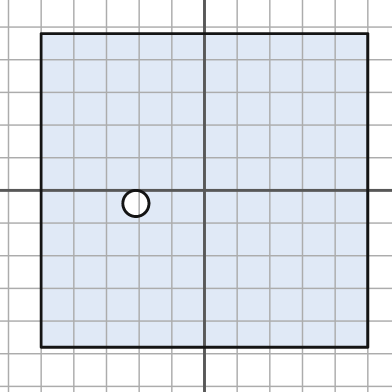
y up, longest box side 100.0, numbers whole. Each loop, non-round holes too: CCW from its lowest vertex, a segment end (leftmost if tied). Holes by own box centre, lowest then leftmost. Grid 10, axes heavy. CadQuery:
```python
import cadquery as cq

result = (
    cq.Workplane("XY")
    .moveTo(-50.0, -48.0)
    .lineTo(50.0, -48.0)
    .lineTo(50.0, 48.0)
    .lineTo(-50.0, 48.0)
    .close()
    .moveTo(-21.0, -4.0)
    .circle(4.0)
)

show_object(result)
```